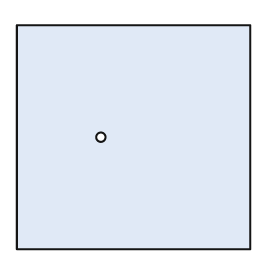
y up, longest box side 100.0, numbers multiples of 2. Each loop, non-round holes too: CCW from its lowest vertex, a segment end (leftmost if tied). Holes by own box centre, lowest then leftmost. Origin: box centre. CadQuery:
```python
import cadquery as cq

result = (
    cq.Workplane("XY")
    .moveTo(-50.0, -48.0)
    .lineTo(50.0, -48.0)
    .lineTo(50.0, 48.0)
    .lineTo(-50.0, 48.0)
    .close()
    .moveTo(-14.0, 0.0)
    .circle(2.0)
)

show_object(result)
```